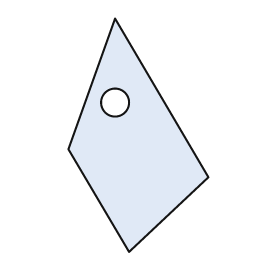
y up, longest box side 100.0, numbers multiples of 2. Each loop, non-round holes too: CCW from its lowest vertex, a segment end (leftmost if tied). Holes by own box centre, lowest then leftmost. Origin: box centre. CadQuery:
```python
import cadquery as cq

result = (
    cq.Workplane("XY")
    .moveTo(-4.0, -50.0)
    .lineTo(30.0, -18.0)
    .lineTo(-10.0, 50.0)
    .lineTo(-30.0, -6.0)
    .close()
    .moveTo(-10.0, 14.0)
    .circle(6.0)
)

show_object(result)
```